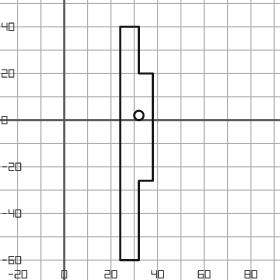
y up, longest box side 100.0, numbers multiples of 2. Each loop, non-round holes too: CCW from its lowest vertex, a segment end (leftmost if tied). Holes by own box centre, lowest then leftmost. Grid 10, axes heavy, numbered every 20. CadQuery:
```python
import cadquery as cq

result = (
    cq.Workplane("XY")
    .moveTo(24.0, -60.0)
    .lineTo(32.0, -60.0)
    .lineTo(32.0, -26.0)
    .lineTo(38.0, -26.0)
    .lineTo(38.0, 20.0)
    .lineTo(32.0, 20.0)
    .lineTo(32.0, 40.0)
    .lineTo(24.0, 40.0)
    .close()
    .moveTo(32.0, 2.0)
    .circle(2.0)
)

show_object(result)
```